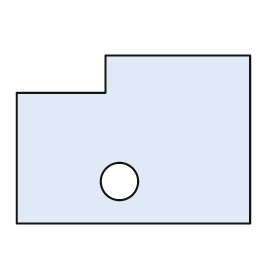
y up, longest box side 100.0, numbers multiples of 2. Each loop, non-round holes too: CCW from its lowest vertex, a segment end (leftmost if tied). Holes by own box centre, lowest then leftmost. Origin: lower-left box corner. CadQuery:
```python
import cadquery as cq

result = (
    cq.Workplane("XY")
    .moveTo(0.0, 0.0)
    .lineTo(100.0, 0.0)
    .lineTo(100.0, 72.0)
    .lineTo(38.0, 72.0)
    .lineTo(38.0, 56.0)
    .lineTo(0.0, 56.0)
    .close()
    .moveTo(44.0, 18.0)
    .circle(8.0)
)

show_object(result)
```